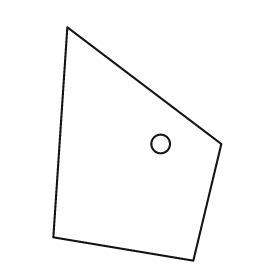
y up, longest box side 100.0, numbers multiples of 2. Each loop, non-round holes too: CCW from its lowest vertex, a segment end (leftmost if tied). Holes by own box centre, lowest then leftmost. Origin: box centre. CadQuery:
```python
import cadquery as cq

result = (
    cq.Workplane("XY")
    .moveTo(24.0, -50.0)
    .lineTo(36.0, 0.0)
    .lineTo(-30.0, 50.0)
    .lineTo(-36.0, -40.0)
    .close()
    .moveTo(10.0, 0.0)
    .circle(4.0)
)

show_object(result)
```